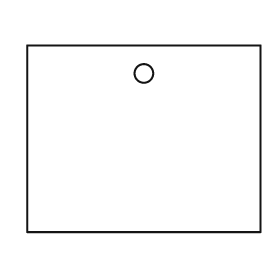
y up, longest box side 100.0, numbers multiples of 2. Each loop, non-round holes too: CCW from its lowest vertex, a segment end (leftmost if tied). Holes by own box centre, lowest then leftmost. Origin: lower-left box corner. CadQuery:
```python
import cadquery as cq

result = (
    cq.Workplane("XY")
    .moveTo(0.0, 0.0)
    .lineTo(100.0, 0.0)
    .lineTo(100.0, 80.0)
    .lineTo(0.0, 80.0)
    .close()
    .moveTo(50.0, 68.0)
    .circle(4.0)
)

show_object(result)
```